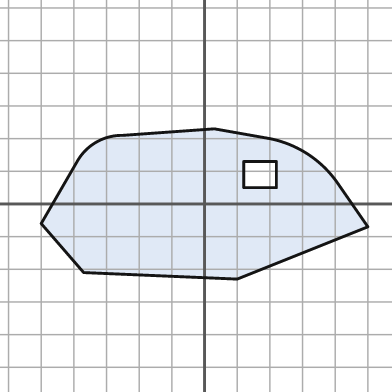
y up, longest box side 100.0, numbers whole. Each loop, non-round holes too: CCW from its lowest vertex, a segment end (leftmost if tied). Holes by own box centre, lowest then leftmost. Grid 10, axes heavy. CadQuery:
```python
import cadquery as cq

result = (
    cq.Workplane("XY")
    .moveTo(10.0, -23.0)
    .lineTo(50.0, -7.0)
    .lineTo(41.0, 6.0)
    .threePointArc((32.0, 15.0), (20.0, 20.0))
    .lineTo(3.0, 23.0)
    .lineTo(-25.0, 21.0)
    .threePointArc((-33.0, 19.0), (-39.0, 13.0))
    .lineTo(-50.0, -6.0)
    .lineTo(-37.0, -21.0)
    .close()
    .moveTo(12.0, 5.0)
    .lineTo(22.0, 5.0)
    .lineTo(22.0, 13.0)
    .lineTo(12.0, 13.0)
    .close()
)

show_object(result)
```